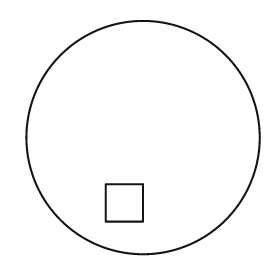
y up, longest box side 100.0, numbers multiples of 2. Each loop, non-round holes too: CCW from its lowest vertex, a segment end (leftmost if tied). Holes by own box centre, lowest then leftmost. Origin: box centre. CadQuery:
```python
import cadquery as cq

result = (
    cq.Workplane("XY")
    .moveTo(0.0, 0.0)
    .circle(50.0)
    .moveTo(-16.0, -36.0)
    .lineTo(0.0, -36.0)
    .lineTo(0.0, -20.0)
    .lineTo(-16.0, -20.0)
    .close()
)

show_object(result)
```